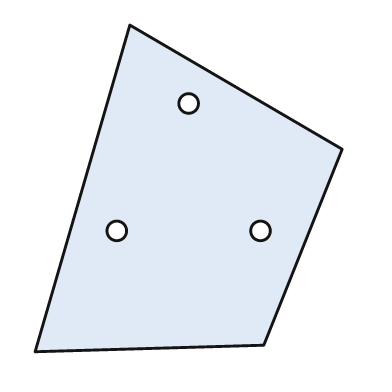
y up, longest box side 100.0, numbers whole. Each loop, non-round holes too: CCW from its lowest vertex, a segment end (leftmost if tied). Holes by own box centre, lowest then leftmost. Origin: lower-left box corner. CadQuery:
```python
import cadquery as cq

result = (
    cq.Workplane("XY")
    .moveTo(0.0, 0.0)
    .lineTo(70.0, 2.0)
    .lineTo(94.0, 62.0)
    .lineTo(29.0, 100.0)
    .close()
    .moveTo(25.0, 37.0)
    .circle(3.0)
    .moveTo(69.0, 37.0)
    .circle(3.0)
    .moveTo(47.0, 76.0)
    .circle(3.0)
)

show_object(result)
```